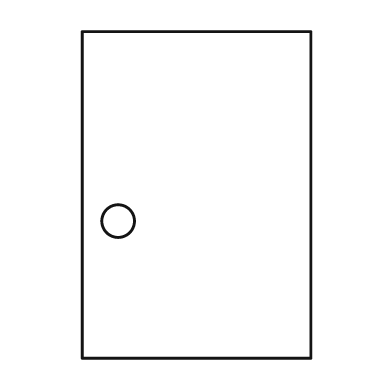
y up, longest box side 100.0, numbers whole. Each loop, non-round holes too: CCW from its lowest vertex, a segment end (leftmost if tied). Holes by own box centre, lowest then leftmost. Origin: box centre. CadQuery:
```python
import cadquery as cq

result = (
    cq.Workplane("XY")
    .moveTo(-35.0, -50.0)
    .lineTo(35.0, -50.0)
    .lineTo(35.0, 50.0)
    .lineTo(-35.0, 50.0)
    .close()
    .moveTo(-24.0, -8.0)
    .circle(5.0)
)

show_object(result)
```